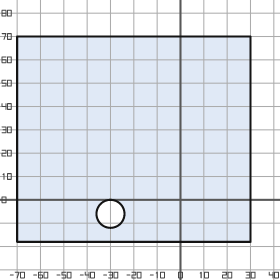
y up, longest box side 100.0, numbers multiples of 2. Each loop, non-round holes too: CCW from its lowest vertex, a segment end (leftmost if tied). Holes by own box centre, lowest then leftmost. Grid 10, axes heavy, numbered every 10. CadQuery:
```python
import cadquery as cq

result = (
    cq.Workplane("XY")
    .moveTo(-70.0, -18.0)
    .lineTo(30.0, -18.0)
    .lineTo(30.0, 70.0)
    .lineTo(-70.0, 70.0)
    .close()
    .moveTo(-30.0, -6.0)
    .circle(6.0)
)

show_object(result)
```